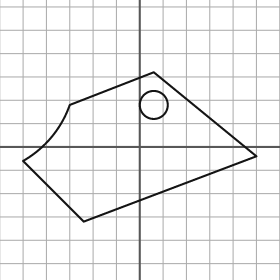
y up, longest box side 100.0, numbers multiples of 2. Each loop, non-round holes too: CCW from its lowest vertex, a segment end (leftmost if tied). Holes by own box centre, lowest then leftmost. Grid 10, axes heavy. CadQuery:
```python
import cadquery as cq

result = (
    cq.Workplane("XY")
    .moveTo(-24.0, -32.0)
    .lineTo(50.0, -4.0)
    .lineTo(6.0, 32.0)
    .lineTo(-30.0, 18.0)
    .threePointArc((-38.0, 4.0), (-50.0, -6.0))
    .close()
    .moveTo(6.0, 18.0)
    .circle(6.0)
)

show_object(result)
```